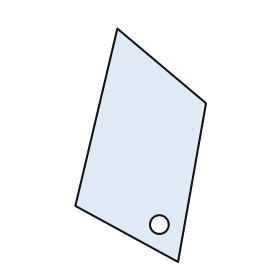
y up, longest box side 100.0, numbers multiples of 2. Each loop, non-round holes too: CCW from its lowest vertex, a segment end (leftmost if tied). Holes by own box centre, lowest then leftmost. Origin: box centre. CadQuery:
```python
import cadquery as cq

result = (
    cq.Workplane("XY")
    .moveTo(16.0, -50.0)
    .lineTo(28.0, 18.0)
    .lineTo(-10.0, 50.0)
    .lineTo(-28.0, -26.0)
    .close()
    .moveTo(8.0, -34.0)
    .circle(4.0)
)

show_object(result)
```